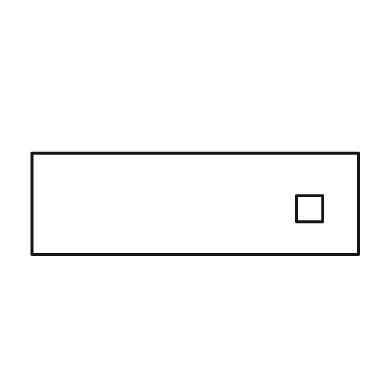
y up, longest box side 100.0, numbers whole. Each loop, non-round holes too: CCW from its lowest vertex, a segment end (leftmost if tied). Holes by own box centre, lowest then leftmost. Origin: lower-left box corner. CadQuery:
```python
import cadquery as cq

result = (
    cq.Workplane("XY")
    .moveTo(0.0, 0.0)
    .lineTo(100.0, 0.0)
    .lineTo(100.0, 31.0)
    .lineTo(0.0, 31.0)
    .close()
    .moveTo(81.0, 10.0)
    .lineTo(89.0, 10.0)
    .lineTo(89.0, 18.0)
    .lineTo(81.0, 18.0)
    .close()
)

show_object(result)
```